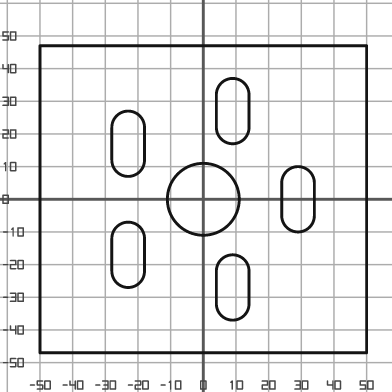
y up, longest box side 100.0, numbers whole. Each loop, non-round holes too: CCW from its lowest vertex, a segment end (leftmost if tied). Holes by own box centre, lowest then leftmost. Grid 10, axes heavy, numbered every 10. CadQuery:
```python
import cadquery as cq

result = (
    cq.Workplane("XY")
    .moveTo(-50.0, -47.0)
    .lineTo(50.0, -47.0)
    .lineTo(50.0, 47.0)
    .lineTo(-50.0, 47.0)
    .close()
    .moveTo(4.0, -32.0)
    .threePointArc((9.0, -37.0), (14.0, -32.0))
    .lineTo(14.0, -22.0)
    .threePointArc((9.0, -17.0), (4.0, -22.0))
    .close()
    .moveTo(-28.0, -22.0)
    .threePointArc((-23.0, -27.0), (-18.0, -22.0))
    .lineTo(-18.0, -12.0)
    .threePointArc((-23.0, -7.0), (-28.0, -12.0))
    .close()
    .moveTo(0.0, 0.0)
    .circle(11.0)
    .moveTo(24.0, -5.0)
    .threePointArc((29.0, -10.0), (34.0, -5.0))
    .lineTo(34.0, 5.0)
    .threePointArc((29.0, 10.0), (24.0, 5.0))
    .close()
    .moveTo(-28.0, 12.0)
    .threePointArc((-23.0, 7.0), (-18.0, 12.0))
    .lineTo(-18.0, 22.0)
    .threePointArc((-23.0, 27.0), (-28.0, 22.0))
    .close()
    .moveTo(4.0, 22.0)
    .threePointArc((9.0, 17.0), (14.0, 22.0))
    .lineTo(14.0, 32.0)
    .threePointArc((9.0, 37.0), (4.0, 32.0))
    .close()
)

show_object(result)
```